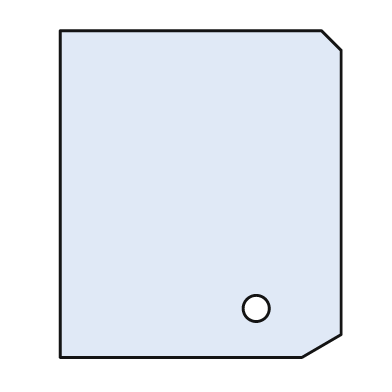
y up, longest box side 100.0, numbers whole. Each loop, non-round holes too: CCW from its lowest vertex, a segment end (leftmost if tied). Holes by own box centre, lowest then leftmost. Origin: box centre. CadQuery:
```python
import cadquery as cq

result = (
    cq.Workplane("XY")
    .moveTo(-43.0, -50.0)
    .lineTo(31.0, -50.0)
    .lineTo(43.0, -43.0)
    .lineTo(43.0, 44.0)
    .lineTo(37.0, 50.0)
    .lineTo(-43.0, 50.0)
    .close()
    .moveTo(17.0, -35.0)
    .circle(4.0)
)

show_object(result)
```